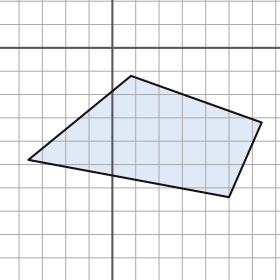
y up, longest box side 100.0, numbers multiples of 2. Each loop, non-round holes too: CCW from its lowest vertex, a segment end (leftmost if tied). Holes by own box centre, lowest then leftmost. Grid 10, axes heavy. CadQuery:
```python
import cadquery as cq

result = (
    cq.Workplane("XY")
    .moveTo(50.0, -64.0)
    .lineTo(64.0, -32.0)
    .lineTo(8.0, -12.0)
    .lineTo(-36.0, -48.0)
    .close()
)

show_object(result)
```